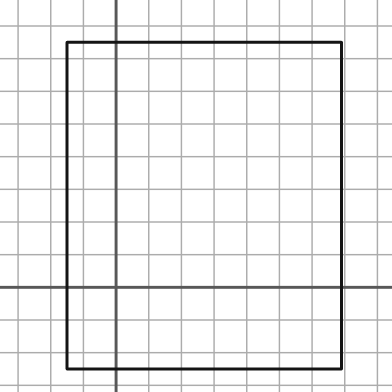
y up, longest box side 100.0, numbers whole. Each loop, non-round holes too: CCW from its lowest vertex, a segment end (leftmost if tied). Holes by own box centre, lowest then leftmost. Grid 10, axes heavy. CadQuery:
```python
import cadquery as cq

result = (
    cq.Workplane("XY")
    .moveTo(-15.0, -25.0)
    .lineTo(69.0, -25.0)
    .lineTo(69.0, 75.0)
    .lineTo(-15.0, 75.0)
    .close()
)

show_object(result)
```